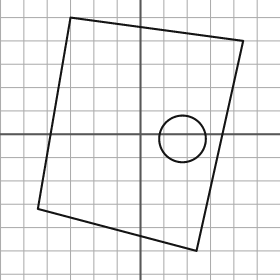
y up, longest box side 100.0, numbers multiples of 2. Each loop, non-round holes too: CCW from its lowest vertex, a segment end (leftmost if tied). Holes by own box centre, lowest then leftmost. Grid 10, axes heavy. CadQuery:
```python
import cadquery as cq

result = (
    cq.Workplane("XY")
    .moveTo(24.0, -50.0)
    .lineTo(44.0, 40.0)
    .lineTo(-30.0, 50.0)
    .lineTo(-44.0, -32.0)
    .close()
    .moveTo(18.0, -2.0)
    .circle(10.0)
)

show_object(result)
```